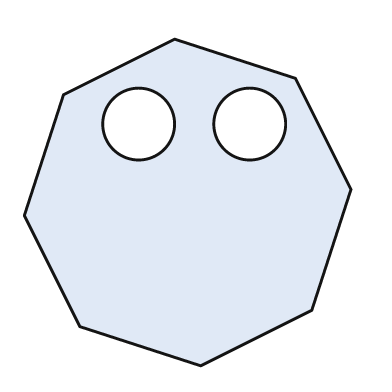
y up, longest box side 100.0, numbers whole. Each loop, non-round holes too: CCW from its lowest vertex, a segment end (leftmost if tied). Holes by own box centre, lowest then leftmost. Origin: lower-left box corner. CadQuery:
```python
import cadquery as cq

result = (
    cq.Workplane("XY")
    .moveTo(54.0, 0.0)
    .lineTo(88.0, 17.0)
    .lineTo(100.0, 54.0)
    .lineTo(83.0, 88.0)
    .lineTo(46.0, 100.0)
    .lineTo(12.0, 83.0)
    .lineTo(0.0, 46.0)
    .lineTo(17.0, 12.0)
    .close()
    .moveTo(35.0, 74.0)
    .circle(11.0)
    .moveTo(69.0, 74.0)
    .circle(11.0)
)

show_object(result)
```